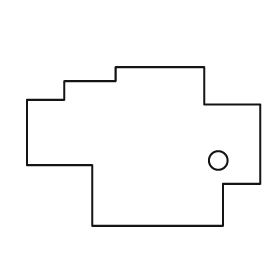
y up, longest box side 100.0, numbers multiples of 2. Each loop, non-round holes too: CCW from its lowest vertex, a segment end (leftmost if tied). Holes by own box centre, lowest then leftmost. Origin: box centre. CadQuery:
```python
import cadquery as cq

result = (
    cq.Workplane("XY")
    .moveTo(-22.0, -34.0)
    .lineTo(34.0, -34.0)
    .lineTo(34.0, -16.0)
    .lineTo(50.0, -16.0)
    .lineTo(50.0, 18.0)
    .lineTo(26.0, 18.0)
    .lineTo(26.0, 34.0)
    .lineTo(-12.0, 34.0)
    .lineTo(-12.0, 28.0)
    .lineTo(-34.0, 28.0)
    .lineTo(-34.0, 20.0)
    .lineTo(-50.0, 20.0)
    .lineTo(-50.0, -8.0)
    .lineTo(-22.0, -8.0)
    .close()
    .moveTo(32.0, -6.0)
    .circle(4.0)
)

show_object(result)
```